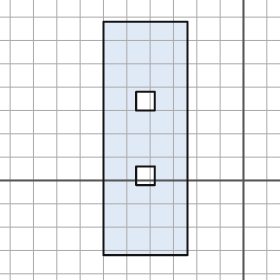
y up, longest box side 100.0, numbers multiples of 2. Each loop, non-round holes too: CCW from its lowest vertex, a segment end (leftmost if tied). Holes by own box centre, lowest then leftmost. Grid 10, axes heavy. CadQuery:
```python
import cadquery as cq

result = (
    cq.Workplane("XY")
    .moveTo(-60.0, -32.0)
    .lineTo(-24.0, -32.0)
    .lineTo(-24.0, 68.0)
    .lineTo(-60.0, 68.0)
    .close()
    .moveTo(-46.0, -2.0)
    .lineTo(-38.0, -2.0)
    .lineTo(-38.0, 6.0)
    .lineTo(-46.0, 6.0)
    .close()
    .moveTo(-46.0, 30.0)
    .lineTo(-38.0, 30.0)
    .lineTo(-38.0, 38.0)
    .lineTo(-46.0, 38.0)
    .close()
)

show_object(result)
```